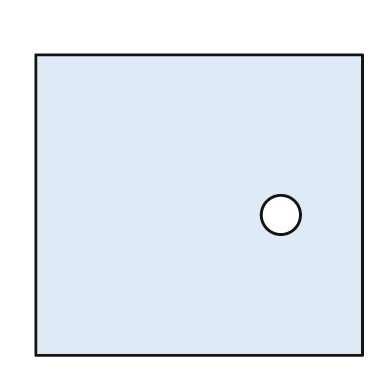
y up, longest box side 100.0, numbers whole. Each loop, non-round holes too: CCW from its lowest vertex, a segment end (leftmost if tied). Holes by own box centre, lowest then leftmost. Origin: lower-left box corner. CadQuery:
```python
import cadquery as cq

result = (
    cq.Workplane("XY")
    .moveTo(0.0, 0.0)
    .lineTo(100.0, 0.0)
    .lineTo(100.0, 92.0)
    .lineTo(0.0, 92.0)
    .close()
    .moveTo(75.0, 43.0)
    .circle(6.0)
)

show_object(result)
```